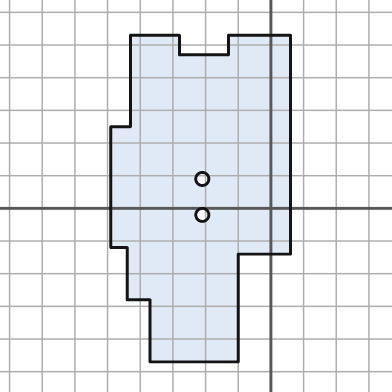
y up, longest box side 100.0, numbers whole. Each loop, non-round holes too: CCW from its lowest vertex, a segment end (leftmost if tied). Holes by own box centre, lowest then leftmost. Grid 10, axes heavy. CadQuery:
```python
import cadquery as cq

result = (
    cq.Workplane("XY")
    .moveTo(-37.0, -47.0)
    .lineTo(-10.0, -47.0)
    .lineTo(-10.0, -14.0)
    .lineTo(6.0, -14.0)
    .lineTo(6.0, 53.0)
    .lineTo(-13.0, 53.0)
    .lineTo(-13.0, 47.0)
    .lineTo(-28.0, 47.0)
    .lineTo(-28.0, 53.0)
    .lineTo(-43.0, 53.0)
    .lineTo(-43.0, 25.0)
    .lineTo(-49.0, 25.0)
    .lineTo(-49.0, -12.0)
    .lineTo(-44.0, -12.0)
    .lineTo(-44.0, -28.0)
    .lineTo(-37.0, -28.0)
    .close()
    .moveTo(-21.0, -2.0)
    .circle(2.0)
    .moveTo(-21.0, 9.0)
    .circle(2.0)
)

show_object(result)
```